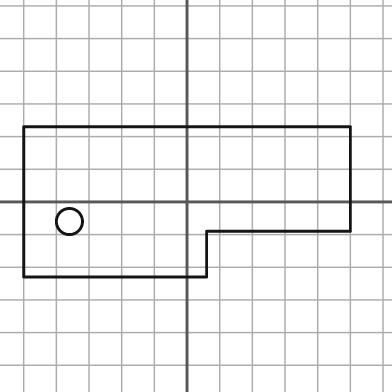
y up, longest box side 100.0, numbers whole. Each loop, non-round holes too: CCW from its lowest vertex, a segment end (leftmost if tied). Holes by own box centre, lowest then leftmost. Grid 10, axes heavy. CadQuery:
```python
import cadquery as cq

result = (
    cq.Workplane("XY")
    .moveTo(-50.0, -23.0)
    .lineTo(6.0, -23.0)
    .lineTo(6.0, -9.0)
    .lineTo(50.0, -9.0)
    .lineTo(50.0, 23.0)
    .lineTo(-50.0, 23.0)
    .close()
    .moveTo(-36.0, -6.0)
    .circle(4.0)
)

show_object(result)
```